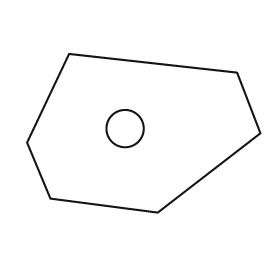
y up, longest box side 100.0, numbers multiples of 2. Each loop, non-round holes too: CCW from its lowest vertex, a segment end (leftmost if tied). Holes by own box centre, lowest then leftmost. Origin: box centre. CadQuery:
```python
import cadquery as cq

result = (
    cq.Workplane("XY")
    .moveTo(6.0, -34.0)
    .lineTo(50.0, 0.0)
    .lineTo(40.0, 26.0)
    .lineTo(-32.0, 34.0)
    .lineTo(-50.0, -4.0)
    .lineTo(-40.0, -28.0)
    .close()
    .moveTo(-8.0, 2.0)
    .circle(8.0)
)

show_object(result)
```